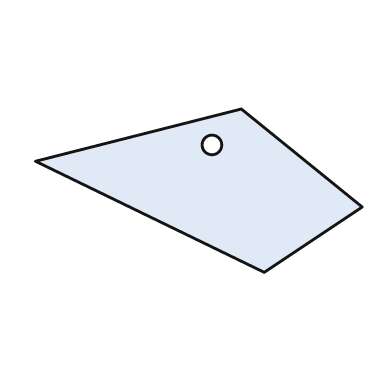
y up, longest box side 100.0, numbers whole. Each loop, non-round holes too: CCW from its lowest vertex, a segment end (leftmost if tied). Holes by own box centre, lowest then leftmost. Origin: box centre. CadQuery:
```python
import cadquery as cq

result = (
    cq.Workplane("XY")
    .moveTo(20.0, -25.0)
    .lineTo(50.0, -5.0)
    .lineTo(13.0, 25.0)
    .lineTo(-50.0, 9.0)
    .close()
    .moveTo(4.0, 14.0)
    .circle(3.0)
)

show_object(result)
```